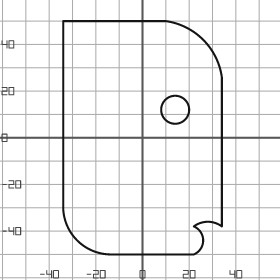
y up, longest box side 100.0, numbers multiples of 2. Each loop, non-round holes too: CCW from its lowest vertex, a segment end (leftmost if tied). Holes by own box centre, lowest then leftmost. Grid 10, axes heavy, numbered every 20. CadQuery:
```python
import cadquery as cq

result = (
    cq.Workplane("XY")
    .moveTo(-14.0, -50.0)
    .lineTo(22.0, -50.0)
    .threePointArc((26.0, -44.0), (22.0, -38.0))
    .threePointArc((28.0, -36.0), (34.0, -38.0))
    .lineTo(34.0, 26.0)
    .threePointArc((26.0, 42.0), (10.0, 50.0))
    .lineTo(-34.0, 50.0)
    .lineTo(-34.0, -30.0)
    .threePointArc((-28.0, -44.0), (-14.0, -50.0))
    .close()
    .moveTo(14.0, 12.0)
    .circle(6.0)
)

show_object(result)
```